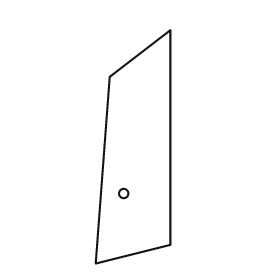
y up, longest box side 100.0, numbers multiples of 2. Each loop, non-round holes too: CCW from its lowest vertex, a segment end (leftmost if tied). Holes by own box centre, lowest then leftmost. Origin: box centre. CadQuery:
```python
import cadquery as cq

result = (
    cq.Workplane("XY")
    .moveTo(-16.0, -50.0)
    .lineTo(16.0, -42.0)
    .lineTo(16.0, 50.0)
    .lineTo(-10.0, 30.0)
    .close()
    .moveTo(-4.0, -20.0)
    .circle(2.0)
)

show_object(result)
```